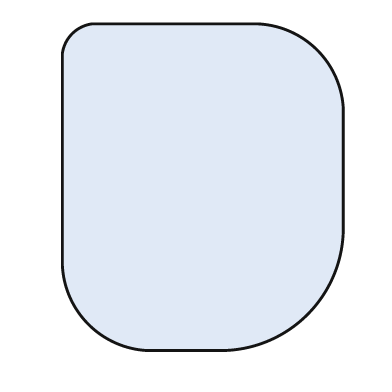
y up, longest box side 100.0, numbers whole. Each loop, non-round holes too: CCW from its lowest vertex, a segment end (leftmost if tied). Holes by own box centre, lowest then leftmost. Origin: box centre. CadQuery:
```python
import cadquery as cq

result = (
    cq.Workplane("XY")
    .moveTo(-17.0, -50.0)
    .lineTo(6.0, -50.0)
    .threePointArc((32.0, -39.0), (43.0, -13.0))
    .lineTo(43.0, 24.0)
    .threePointArc((35.0, 42.0), (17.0, 50.0))
    .lineTo(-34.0, 50.0)
    .threePointArc((-40.0, 47.0), (-43.0, 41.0))
    .lineTo(-43.0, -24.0)
    .threePointArc((-35.0, -42.0), (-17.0, -50.0))
    .close()
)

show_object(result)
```